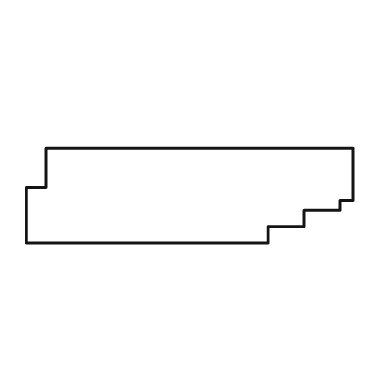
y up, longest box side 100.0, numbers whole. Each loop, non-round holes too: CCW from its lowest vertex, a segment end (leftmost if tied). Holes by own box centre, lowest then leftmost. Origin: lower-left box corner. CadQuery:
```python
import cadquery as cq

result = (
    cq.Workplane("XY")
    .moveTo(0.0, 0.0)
    .lineTo(74.0, 0.0)
    .lineTo(74.0, 5.0)
    .lineTo(85.0, 5.0)
    .lineTo(85.0, 10.0)
    .lineTo(96.0, 10.0)
    .lineTo(96.0, 13.0)
    .lineTo(100.0, 13.0)
    .lineTo(100.0, 29.0)
    .lineTo(6.0, 29.0)
    .lineTo(6.0, 17.0)
    .lineTo(0.0, 17.0)
    .close()
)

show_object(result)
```